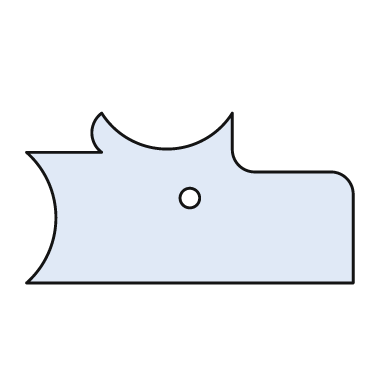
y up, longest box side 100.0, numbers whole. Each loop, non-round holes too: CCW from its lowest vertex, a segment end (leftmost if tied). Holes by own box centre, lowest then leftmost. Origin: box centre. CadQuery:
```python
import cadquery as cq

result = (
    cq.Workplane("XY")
    .moveTo(-50.0, -26.0)
    .lineTo(50.0, -26.0)
    .lineTo(50.0, 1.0)
    .threePointArc((48.0, 6.0), (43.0, 8.0))
    .lineTo(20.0, 8.0)
    .threePointArc((15.0, 10.0), (13.0, 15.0))
    .lineTo(13.0, 26.0)
    .threePointArc((-7.0, 15.0), (-27.0, 26.0))
    .threePointArc((-30.0, 20.0), (-27.0, 14.0))
    .lineTo(-50.0, 14.0)
    .threePointArc((-41.0, -6.0), (-50.0, -26.0))
    .close()
    .moveTo(0.0, 0.0)
    .circle(3.0)
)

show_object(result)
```